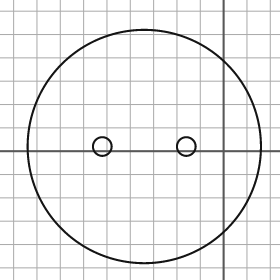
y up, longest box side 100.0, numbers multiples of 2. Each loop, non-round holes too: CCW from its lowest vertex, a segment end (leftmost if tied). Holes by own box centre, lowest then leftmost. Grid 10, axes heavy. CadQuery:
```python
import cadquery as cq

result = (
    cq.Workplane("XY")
    .moveTo(-34.0, 2.0)
    .circle(50.0)
    .moveTo(-52.0, 2.0)
    .circle(4.0)
    .moveTo(-16.0, 2.0)
    .circle(4.0)
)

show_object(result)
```